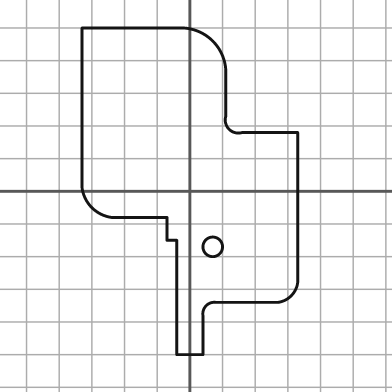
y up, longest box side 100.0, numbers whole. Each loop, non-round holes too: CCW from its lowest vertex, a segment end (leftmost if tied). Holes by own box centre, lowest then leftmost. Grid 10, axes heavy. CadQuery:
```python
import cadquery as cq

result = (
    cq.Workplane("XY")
    .moveTo(-4.0, -50.0)
    .lineTo(4.0, -50.0)
    .lineTo(4.0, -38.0)
    .threePointArc((5.0, -35.0), (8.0, -34.0))
    .lineTo(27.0, -34.0)
    .threePointArc((31.0, -32.0), (33.0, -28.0))
    .lineTo(33.0, 18.0)
    .lineTo(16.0, 18.0)
    .threePointArc((12.0, 19.0), (11.0, 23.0))
    .lineTo(11.0, 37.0)
    .threePointArc((7.0, 46.0), (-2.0, 50.0))
    .lineTo(-33.0, 50.0)
    .lineTo(-33.0, 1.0)
    .threePointArc((-30.0, -5.0), (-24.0, -8.0))
    .lineTo(-7.0, -8.0)
    .lineTo(-7.0, -15.0)
    .lineTo(-4.0, -15.0)
    .close()
    .moveTo(7.0, -17.0)
    .circle(3.0)
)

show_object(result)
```